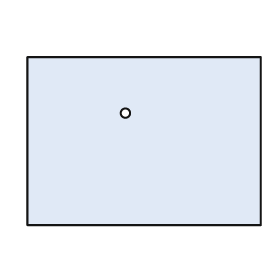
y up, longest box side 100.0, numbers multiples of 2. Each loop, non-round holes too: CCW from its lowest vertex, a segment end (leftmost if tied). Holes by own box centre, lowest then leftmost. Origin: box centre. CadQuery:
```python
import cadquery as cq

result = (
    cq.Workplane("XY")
    .moveTo(-50.0, -36.0)
    .lineTo(50.0, -36.0)
    .lineTo(50.0, 36.0)
    .lineTo(-50.0, 36.0)
    .close()
    .moveTo(-8.0, 12.0)
    .circle(2.0)
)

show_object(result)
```